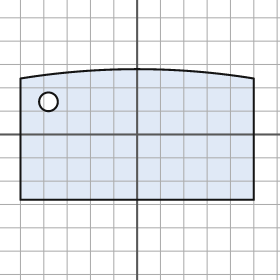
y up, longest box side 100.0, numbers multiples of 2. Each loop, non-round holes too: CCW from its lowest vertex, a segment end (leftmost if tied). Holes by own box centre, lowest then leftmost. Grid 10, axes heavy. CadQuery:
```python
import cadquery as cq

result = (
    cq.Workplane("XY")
    .moveTo(-50.0, -28.0)
    .lineTo(50.0, -28.0)
    .lineTo(50.0, 24.0)
    .threePointArc((0.0, 28.0), (-50.0, 24.0))
    .close()
    .moveTo(-38.0, 14.0)
    .circle(4.0)
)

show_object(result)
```